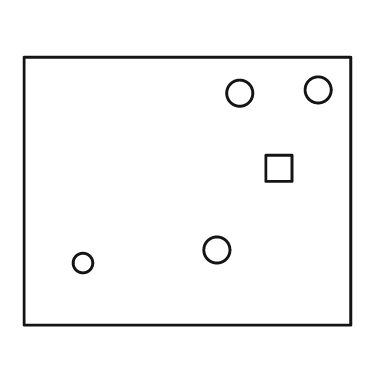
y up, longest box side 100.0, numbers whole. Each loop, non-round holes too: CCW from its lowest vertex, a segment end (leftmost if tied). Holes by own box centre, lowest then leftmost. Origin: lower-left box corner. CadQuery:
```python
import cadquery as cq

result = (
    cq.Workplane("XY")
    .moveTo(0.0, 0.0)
    .lineTo(100.0, 0.0)
    .lineTo(100.0, 82.0)
    .lineTo(0.0, 82.0)
    .close()
    .moveTo(18.0, 19.0)
    .circle(3.0)
    .moveTo(59.0, 23.0)
    .circle(4.0)
    .moveTo(74.0, 44.0)
    .lineTo(82.0, 44.0)
    .lineTo(82.0, 52.0)
    .lineTo(74.0, 52.0)
    .close()
    .moveTo(66.0, 71.0)
    .circle(4.0)
    .moveTo(90.0, 72.0)
    .circle(4.0)
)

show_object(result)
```